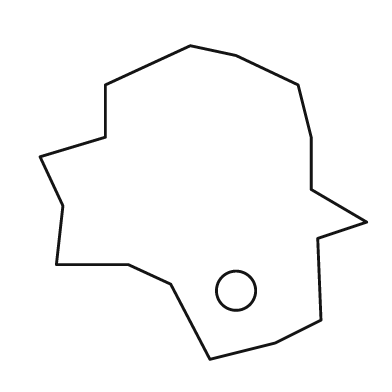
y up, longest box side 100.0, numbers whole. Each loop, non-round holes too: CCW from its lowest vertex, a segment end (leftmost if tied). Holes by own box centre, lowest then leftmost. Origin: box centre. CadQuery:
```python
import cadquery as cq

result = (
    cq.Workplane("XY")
    .moveTo(2.0, -48.0)
    .lineTo(22.0, -43.0)
    .lineTo(36.0, -36.0)
    .lineTo(35.0, -11.0)
    .lineTo(50.0, -6.0)
    .lineTo(33.0, 4.0)
    .lineTo(33.0, 20.0)
    .lineTo(29.0, 36.0)
    .lineTo(10.0, 45.0)
    .lineTo(-4.0, 48.0)
    .lineTo(-30.0, 36.0)
    .lineTo(-30.0, 20.0)
    .lineTo(-50.0, 14.0)
    .lineTo(-43.0, -1.0)
    .lineTo(-45.0, -19.0)
    .lineTo(-23.0, -19.0)
    .lineTo(-10.0, -25.0)
    .close()
    .moveTo(10.0, -27.0)
    .circle(6.0)
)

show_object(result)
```